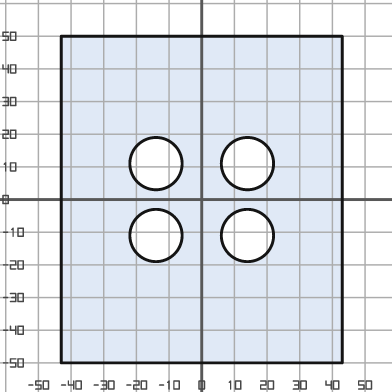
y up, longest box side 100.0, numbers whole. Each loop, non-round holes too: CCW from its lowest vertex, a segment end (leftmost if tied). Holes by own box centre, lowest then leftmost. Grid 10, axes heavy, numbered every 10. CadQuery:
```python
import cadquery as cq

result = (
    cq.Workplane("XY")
    .moveTo(-43.0, -50.0)
    .lineTo(43.0, -50.0)
    .lineTo(43.0, 50.0)
    .lineTo(-43.0, 50.0)
    .close()
    .moveTo(-14.0, -11.0)
    .circle(8.0)
    .moveTo(14.0, -11.0)
    .circle(8.0)
    .moveTo(-14.0, 11.0)
    .circle(8.0)
    .moveTo(14.0, 11.0)
    .circle(8.0)
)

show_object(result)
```